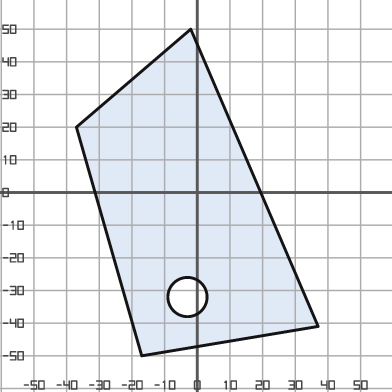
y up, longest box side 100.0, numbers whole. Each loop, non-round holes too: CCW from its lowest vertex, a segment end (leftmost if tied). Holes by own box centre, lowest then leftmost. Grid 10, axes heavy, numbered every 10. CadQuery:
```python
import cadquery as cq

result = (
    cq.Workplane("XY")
    .moveTo(-17.0, -50.0)
    .lineTo(37.0, -41.0)
    .lineTo(-2.0, 50.0)
    .lineTo(-37.0, 20.0)
    .close()
    .moveTo(-3.0, -32.0)
    .circle(6.0)
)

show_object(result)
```